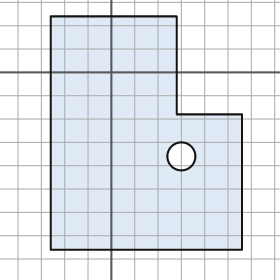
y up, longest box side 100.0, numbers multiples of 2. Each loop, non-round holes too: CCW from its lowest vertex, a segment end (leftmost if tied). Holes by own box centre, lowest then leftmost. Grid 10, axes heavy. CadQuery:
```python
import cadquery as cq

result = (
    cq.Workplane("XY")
    .moveTo(-26.0, -76.0)
    .lineTo(56.0, -76.0)
    .lineTo(56.0, -18.0)
    .lineTo(28.0, -18.0)
    .lineTo(28.0, 24.0)
    .lineTo(-26.0, 24.0)
    .close()
    .moveTo(30.0, -36.0)
    .circle(6.0)
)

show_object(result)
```